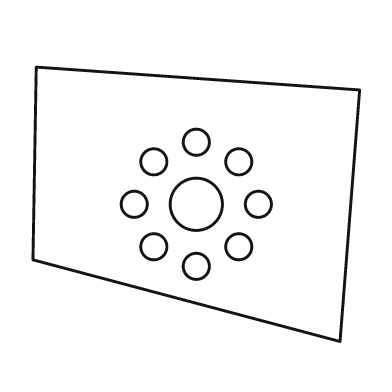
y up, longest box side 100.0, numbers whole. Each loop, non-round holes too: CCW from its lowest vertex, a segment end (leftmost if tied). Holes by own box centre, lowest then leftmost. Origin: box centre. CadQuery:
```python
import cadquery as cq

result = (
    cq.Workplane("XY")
    .moveTo(44.0, -42.0)
    .lineTo(50.0, 35.0)
    .lineTo(-49.0, 42.0)
    .lineTo(-50.0, -17.0)
    .close()
    .moveTo(0.0, -19.0)
    .circle(4.0)
    .moveTo(-13.0, -13.0)
    .circle(4.0)
    .moveTo(13.0, -13.0)
    .circle(4.0)
    .moveTo(-19.0, 0.0)
    .circle(4.0)
    .moveTo(0.0, 0.0)
    .circle(8.0)
    .moveTo(19.0, 0.0)
    .circle(4.0)
    .moveTo(-13.0, 13.0)
    .circle(4.0)
    .moveTo(13.0, 13.0)
    .circle(4.0)
    .moveTo(0.0, 19.0)
    .circle(4.0)
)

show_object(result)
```